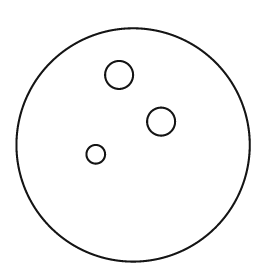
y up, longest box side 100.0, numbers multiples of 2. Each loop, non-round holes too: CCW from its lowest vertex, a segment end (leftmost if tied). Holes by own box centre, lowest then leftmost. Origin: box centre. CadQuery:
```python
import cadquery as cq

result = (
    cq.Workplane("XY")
    .moveTo(0.0, 0.0)
    .circle(50.0)
    .moveTo(-16.0, -4.0)
    .circle(4.0)
    .moveTo(12.0, 10.0)
    .circle(6.0)
    .moveTo(-6.0, 30.0)
    .circle(6.0)
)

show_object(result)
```